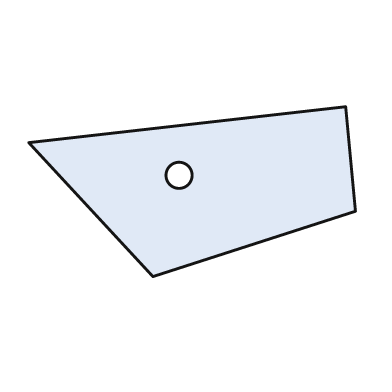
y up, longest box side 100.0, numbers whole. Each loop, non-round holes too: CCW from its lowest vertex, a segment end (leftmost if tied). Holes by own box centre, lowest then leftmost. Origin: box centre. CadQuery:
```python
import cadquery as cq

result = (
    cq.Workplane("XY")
    .moveTo(-12.0, -26.0)
    .lineTo(50.0, -6.0)
    .lineTo(47.0, 26.0)
    .lineTo(-50.0, 15.0)
    .close()
    .moveTo(-4.0, 5.0)
    .circle(4.0)
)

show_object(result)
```